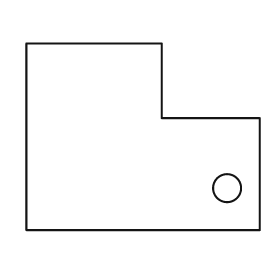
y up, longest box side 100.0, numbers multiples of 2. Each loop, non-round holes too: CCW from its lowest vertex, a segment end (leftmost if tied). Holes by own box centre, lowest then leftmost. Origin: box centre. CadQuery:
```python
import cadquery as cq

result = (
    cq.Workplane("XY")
    .moveTo(-50.0, -40.0)
    .lineTo(50.0, -40.0)
    .lineTo(50.0, 8.0)
    .lineTo(8.0, 8.0)
    .lineTo(8.0, 40.0)
    .lineTo(-50.0, 40.0)
    .close()
    .moveTo(36.0, -22.0)
    .circle(6.0)
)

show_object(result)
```